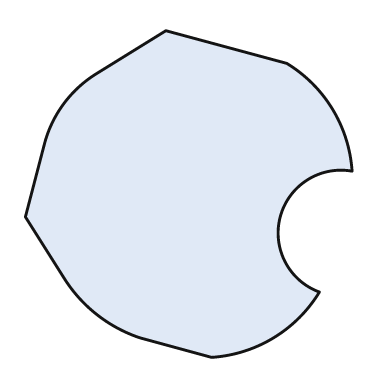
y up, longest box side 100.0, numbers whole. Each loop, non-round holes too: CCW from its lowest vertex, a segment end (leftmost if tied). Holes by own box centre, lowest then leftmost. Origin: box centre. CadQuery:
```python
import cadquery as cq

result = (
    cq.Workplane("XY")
    .moveTo(7.0, -50.0)
    .threePointArc((26.0, -44.0), (40.0, -30.0))
    .threePointArc((28.0, -7.0), (50.0, 7.0))
    .threePointArc((44.0, 26.0), (30.0, 40.0))
    .lineTo(-7.0, 50.0)
    .lineTo(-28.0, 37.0)
    .threePointArc((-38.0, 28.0), (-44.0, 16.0))
    .lineTo(-50.0, -7.0)
    .lineTo(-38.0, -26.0)
    .threePointArc((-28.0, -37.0), (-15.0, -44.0))
    .close()
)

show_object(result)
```